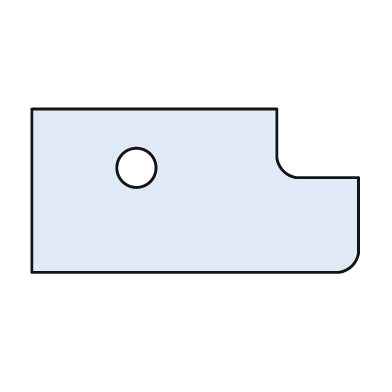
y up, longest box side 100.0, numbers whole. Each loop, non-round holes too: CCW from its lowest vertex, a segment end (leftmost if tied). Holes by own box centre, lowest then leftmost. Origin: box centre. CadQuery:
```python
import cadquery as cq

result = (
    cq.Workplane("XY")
    .moveTo(-50.0, -25.0)
    .lineTo(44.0, -25.0)
    .threePointArc((48.0, -23.0), (50.0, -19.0))
    .lineTo(50.0, 4.0)
    .lineTo(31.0, 4.0)
    .threePointArc((27.0, 6.0), (25.0, 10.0))
    .lineTo(25.0, 25.0)
    .lineTo(-50.0, 25.0)
    .close()
    .moveTo(-18.0, 7.0)
    .circle(6.0)
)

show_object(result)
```